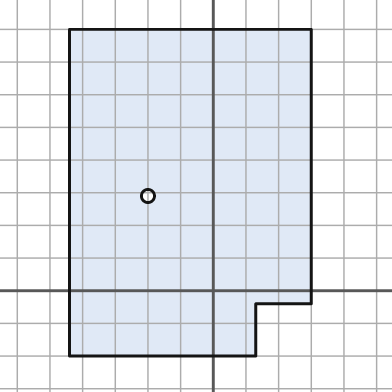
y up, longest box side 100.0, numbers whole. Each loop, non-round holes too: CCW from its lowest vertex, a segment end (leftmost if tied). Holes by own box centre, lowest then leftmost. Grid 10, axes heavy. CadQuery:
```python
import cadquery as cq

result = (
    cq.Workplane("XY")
    .moveTo(-44.0, -20.0)
    .lineTo(13.0, -20.0)
    .lineTo(13.0, -4.0)
    .lineTo(30.0, -4.0)
    .lineTo(30.0, 80.0)
    .lineTo(-44.0, 80.0)
    .close()
    .moveTo(-20.0, 29.0)
    .circle(2.0)
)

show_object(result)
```